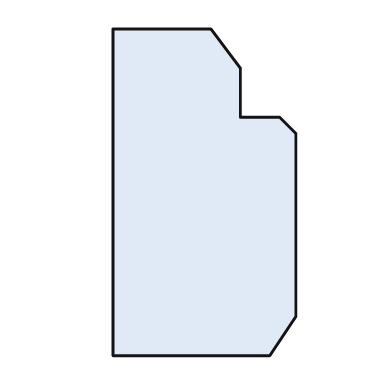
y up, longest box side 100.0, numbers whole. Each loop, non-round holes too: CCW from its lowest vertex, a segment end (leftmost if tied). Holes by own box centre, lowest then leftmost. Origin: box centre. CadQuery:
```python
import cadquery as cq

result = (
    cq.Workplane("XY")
    .moveTo(-28.0, -50.0)
    .lineTo(20.0, -50.0)
    .lineTo(28.0, -38.0)
    .lineTo(28.0, 18.0)
    .lineTo(23.0, 23.0)
    .lineTo(11.0, 23.0)
    .lineTo(11.0, 38.0)
    .lineTo(2.0, 50.0)
    .lineTo(-28.0, 50.0)
    .close()
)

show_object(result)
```